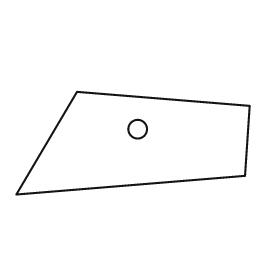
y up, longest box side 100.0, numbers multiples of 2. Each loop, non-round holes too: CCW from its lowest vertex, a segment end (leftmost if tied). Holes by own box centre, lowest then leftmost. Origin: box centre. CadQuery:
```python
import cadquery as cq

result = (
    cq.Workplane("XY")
    .moveTo(-50.0, -22.0)
    .lineTo(48.0, -14.0)
    .lineTo(50.0, 16.0)
    .lineTo(-24.0, 22.0)
    .close()
    .moveTo(2.0, 6.0)
    .circle(4.0)
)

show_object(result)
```